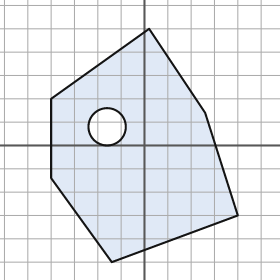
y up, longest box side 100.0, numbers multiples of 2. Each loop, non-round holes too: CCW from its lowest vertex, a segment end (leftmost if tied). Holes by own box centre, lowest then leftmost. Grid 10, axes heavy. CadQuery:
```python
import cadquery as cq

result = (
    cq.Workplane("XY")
    .moveTo(-14.0, -50.0)
    .lineTo(40.0, -30.0)
    .lineTo(26.0, 14.0)
    .lineTo(2.0, 50.0)
    .lineTo(-40.0, 20.0)
    .lineTo(-40.0, -14.0)
    .close()
    .moveTo(-16.0, 8.0)
    .circle(8.0)
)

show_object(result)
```